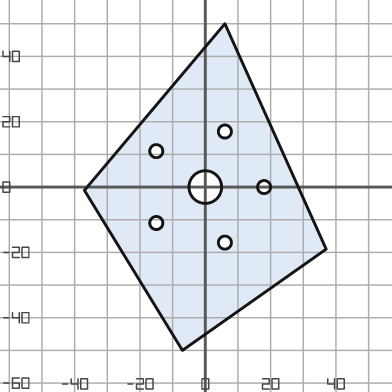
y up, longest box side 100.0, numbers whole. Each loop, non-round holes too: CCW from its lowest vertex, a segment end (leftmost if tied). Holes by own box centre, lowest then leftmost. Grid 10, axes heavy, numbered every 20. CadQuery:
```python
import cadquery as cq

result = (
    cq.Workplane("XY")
    .moveTo(-7.0, -50.0)
    .lineTo(37.0, -19.0)
    .lineTo(6.0, 50.0)
    .lineTo(-37.0, -1.0)
    .close()
    .moveTo(6.0, -17.0)
    .circle(2.0)
    .moveTo(-15.0, -11.0)
    .circle(2.0)
    .moveTo(0.0, 0.0)
    .circle(5.0)
    .moveTo(18.0, 0.0)
    .circle(2.0)
    .moveTo(-15.0, 11.0)
    .circle(2.0)
    .moveTo(6.0, 17.0)
    .circle(2.0)
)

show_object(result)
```